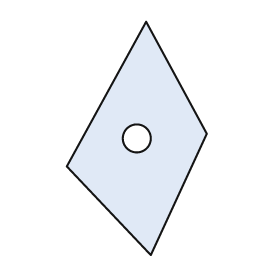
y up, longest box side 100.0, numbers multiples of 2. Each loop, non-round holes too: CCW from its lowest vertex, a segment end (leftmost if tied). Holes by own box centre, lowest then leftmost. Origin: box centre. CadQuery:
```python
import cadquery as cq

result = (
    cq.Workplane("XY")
    .moveTo(6.0, -50.0)
    .lineTo(30.0, 2.0)
    .lineTo(4.0, 50.0)
    .lineTo(-30.0, -12.0)
    .close()
    .moveTo(0.0, 0.0)
    .circle(6.0)
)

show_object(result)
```